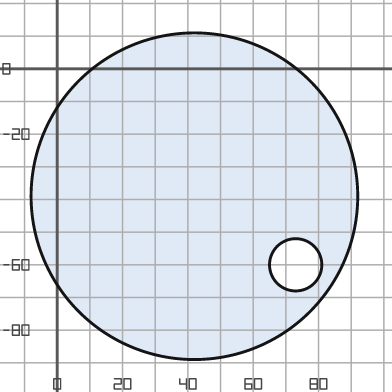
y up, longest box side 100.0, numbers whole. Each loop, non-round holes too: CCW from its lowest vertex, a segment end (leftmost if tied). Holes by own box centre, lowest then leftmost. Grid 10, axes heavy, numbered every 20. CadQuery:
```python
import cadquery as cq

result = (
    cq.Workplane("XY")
    .moveTo(42.0, -39.0)
    .circle(50.0)
    .moveTo(73.0, -60.0)
    .circle(8.0)
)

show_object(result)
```